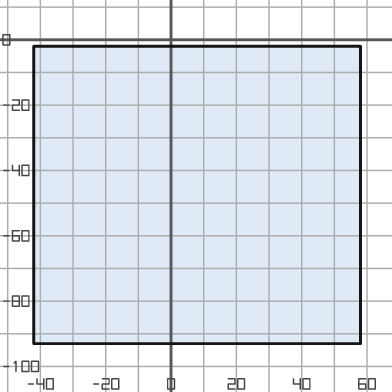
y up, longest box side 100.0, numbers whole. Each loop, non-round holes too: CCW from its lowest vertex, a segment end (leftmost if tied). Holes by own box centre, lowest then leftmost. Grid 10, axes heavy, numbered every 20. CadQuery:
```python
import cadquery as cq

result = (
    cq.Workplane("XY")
    .moveTo(-42.0, -93.0)
    .lineTo(58.0, -93.0)
    .lineTo(58.0, -2.0)
    .lineTo(-42.0, -2.0)
    .close()
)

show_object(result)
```